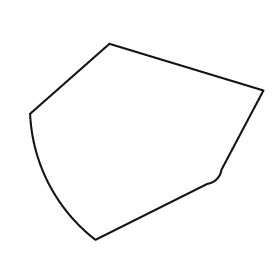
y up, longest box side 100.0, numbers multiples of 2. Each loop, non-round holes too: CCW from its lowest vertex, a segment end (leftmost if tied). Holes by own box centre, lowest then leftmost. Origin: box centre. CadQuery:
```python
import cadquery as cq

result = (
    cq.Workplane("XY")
    .moveTo(-22.0, -42.0)
    .lineTo(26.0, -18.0)
    .threePointArc((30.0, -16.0), (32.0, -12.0))
    .lineTo(50.0, 22.0)
    .lineTo(-16.0, 42.0)
    .lineTo(-50.0, 12.0)
    .threePointArc((-42.0, -18.0), (-22.0, -42.0))
    .close()
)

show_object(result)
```